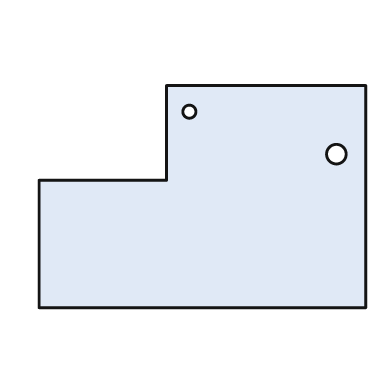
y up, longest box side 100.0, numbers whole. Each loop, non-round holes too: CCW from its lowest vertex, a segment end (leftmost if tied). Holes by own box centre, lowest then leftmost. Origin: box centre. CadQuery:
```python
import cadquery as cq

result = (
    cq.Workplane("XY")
    .moveTo(-50.0, -34.0)
    .lineTo(50.0, -34.0)
    .lineTo(50.0, 34.0)
    .lineTo(-11.0, 34.0)
    .lineTo(-11.0, 5.0)
    .lineTo(-50.0, 5.0)
    .close()
    .moveTo(41.0, 13.0)
    .circle(3.0)
    .moveTo(-4.0, 26.0)
    .circle(2.0)
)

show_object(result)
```